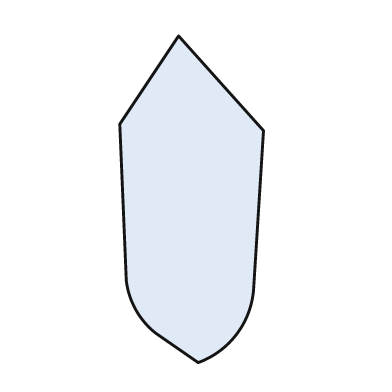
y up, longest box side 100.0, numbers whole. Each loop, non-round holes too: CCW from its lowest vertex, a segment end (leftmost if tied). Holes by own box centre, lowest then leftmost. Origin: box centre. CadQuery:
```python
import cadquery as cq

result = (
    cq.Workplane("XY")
    .moveTo(2.0, -50.0)
    .threePointArc((14.0, -41.0), (19.0, -27.0))
    .lineTo(22.0, 21.0)
    .lineTo(-4.0, 50.0)
    .lineTo(-22.0, 23.0)
    .lineTo(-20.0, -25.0)
    .threePointArc((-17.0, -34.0), (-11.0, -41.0))
    .close()
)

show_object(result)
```